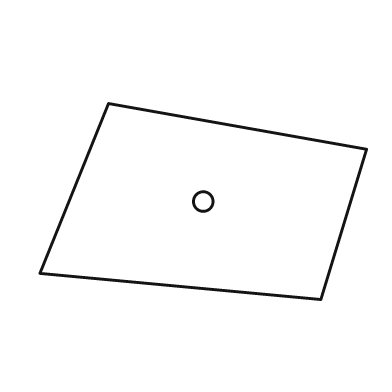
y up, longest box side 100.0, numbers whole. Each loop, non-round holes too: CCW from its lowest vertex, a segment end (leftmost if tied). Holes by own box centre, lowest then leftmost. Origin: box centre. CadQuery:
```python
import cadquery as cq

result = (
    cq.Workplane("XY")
    .moveTo(36.0, -30.0)
    .lineTo(50.0, 16.0)
    .lineTo(-29.0, 30.0)
    .lineTo(-50.0, -22.0)
    .close()
    .moveTo(0.0, 0.0)
    .circle(3.0)
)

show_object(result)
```